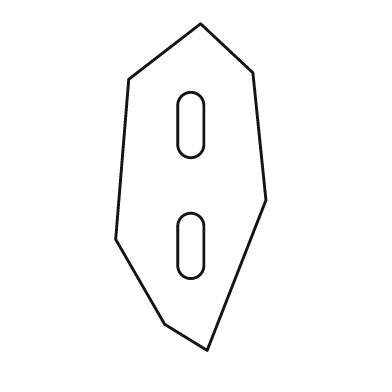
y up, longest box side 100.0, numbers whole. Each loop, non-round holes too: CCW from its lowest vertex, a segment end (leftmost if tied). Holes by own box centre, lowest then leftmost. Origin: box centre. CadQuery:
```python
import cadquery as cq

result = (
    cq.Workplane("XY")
    .moveTo(5.0, -50.0)
    .lineTo(23.0, -4.0)
    .lineTo(19.0, 35.0)
    .lineTo(3.0, 50.0)
    .lineTo(-19.0, 33.0)
    .lineTo(-23.0, -16.0)
    .lineTo(-8.0, -42.0)
    .close()
    .moveTo(-4.0, -24.0)
    .threePointArc((0.0, -28.0), (4.0, -24.0))
    .lineTo(4.0, -12.0)
    .threePointArc((0.0, -8.0), (-4.0, -12.0))
    .close()
    .moveTo(-4.0, 13.0)
    .threePointArc((0.0, 9.0), (4.0, 13.0))
    .lineTo(4.0, 25.0)
    .threePointArc((0.0, 29.0), (-4.0, 25.0))
    .close()
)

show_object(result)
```